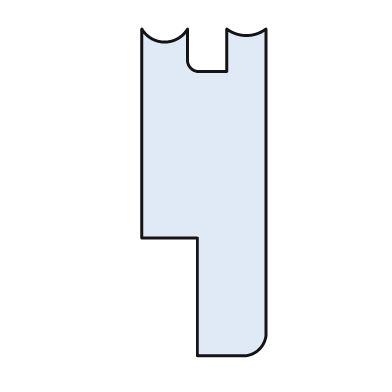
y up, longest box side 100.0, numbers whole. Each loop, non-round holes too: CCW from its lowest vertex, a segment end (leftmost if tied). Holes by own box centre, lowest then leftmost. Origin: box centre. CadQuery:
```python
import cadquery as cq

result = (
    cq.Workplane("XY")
    .moveTo(-2.0, -50.0)
    .lineTo(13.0, -50.0)
    .threePointArc((17.0, -48.0), (19.0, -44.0))
    .lineTo(19.0, 50.0)
    .threePointArc((13.0, 48.0), (7.0, 50.0))
    .lineTo(7.0, 37.0)
    .lineTo(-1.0, 37.0)
    .threePointArc((-4.0, 38.0), (-5.0, 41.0))
    .lineTo(-5.0, 50.0)
    .threePointArc((-12.0, 46.0), (-19.0, 50.0))
    .lineTo(-19.0, -14.0)
    .lineTo(-2.0, -14.0)
    .close()
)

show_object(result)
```